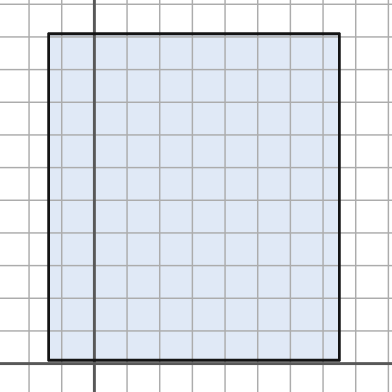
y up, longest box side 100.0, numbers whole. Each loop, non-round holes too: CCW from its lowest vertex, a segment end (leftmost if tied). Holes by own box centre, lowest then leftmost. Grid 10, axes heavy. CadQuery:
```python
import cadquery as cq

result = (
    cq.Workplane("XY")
    .moveTo(-14.0, 1.0)
    .lineTo(75.0, 1.0)
    .lineTo(75.0, 101.0)
    .lineTo(-14.0, 101.0)
    .close()
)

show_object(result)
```